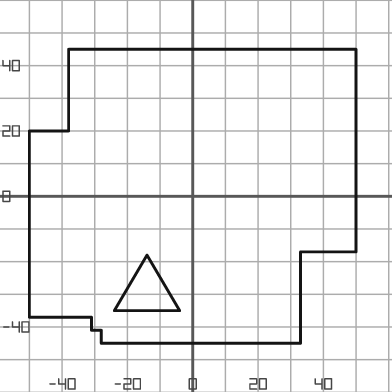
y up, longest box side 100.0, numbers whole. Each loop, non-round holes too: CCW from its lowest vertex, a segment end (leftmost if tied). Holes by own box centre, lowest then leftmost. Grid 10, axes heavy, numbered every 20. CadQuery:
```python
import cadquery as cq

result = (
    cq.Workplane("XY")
    .moveTo(-28.0, -45.0)
    .lineTo(33.0, -45.0)
    .lineTo(33.0, -17.0)
    .lineTo(50.0, -17.0)
    .lineTo(50.0, 45.0)
    .lineTo(-38.0, 45.0)
    .lineTo(-38.0, 20.0)
    .lineTo(-50.0, 20.0)
    .lineTo(-50.0, -37.0)
    .lineTo(-31.0, -37.0)
    .lineTo(-31.0, -41.0)
    .lineTo(-28.0, -41.0)
    .close()
    .moveTo(-24.0, -35.0)
    .lineTo(-4.0, -35.0)
    .lineTo(-14.0, -18.0)
    .close()
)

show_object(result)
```